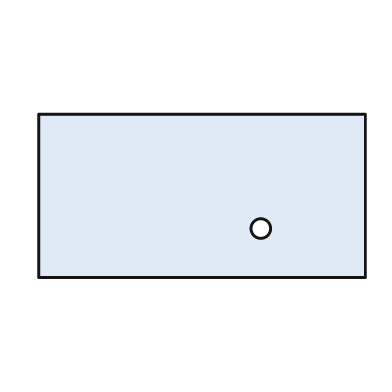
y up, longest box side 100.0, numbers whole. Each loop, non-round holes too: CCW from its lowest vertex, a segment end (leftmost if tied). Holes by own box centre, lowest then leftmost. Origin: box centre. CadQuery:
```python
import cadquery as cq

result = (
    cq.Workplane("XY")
    .moveTo(-50.0, -25.0)
    .lineTo(50.0, -25.0)
    .lineTo(50.0, 25.0)
    .lineTo(-50.0, 25.0)
    .close()
    .moveTo(18.0, -10.0)
    .circle(3.0)
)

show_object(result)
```